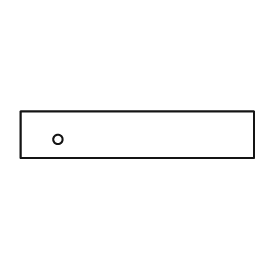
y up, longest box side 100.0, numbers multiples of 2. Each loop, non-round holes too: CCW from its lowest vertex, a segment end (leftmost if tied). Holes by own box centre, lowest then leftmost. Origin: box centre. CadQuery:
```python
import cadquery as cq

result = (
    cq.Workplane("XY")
    .moveTo(-50.0, -10.0)
    .lineTo(50.0, -10.0)
    .lineTo(50.0, 10.0)
    .lineTo(-50.0, 10.0)
    .close()
    .moveTo(-34.0, -2.0)
    .circle(2.0)
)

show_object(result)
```